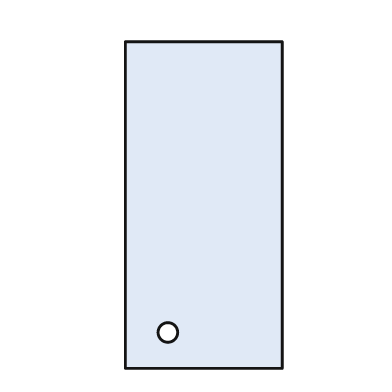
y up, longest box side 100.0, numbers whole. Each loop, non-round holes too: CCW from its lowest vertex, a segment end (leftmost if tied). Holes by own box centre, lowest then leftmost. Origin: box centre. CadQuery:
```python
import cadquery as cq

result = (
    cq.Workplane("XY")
    .moveTo(-24.0, -50.0)
    .lineTo(24.0, -50.0)
    .lineTo(24.0, 50.0)
    .lineTo(-24.0, 50.0)
    .close()
    .moveTo(-11.0, -39.0)
    .circle(3.0)
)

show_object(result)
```